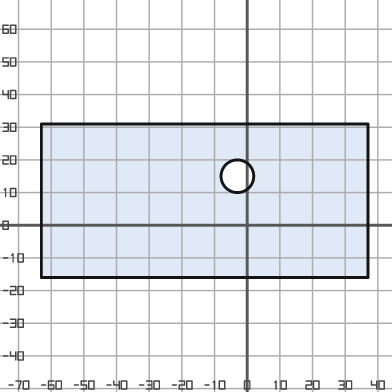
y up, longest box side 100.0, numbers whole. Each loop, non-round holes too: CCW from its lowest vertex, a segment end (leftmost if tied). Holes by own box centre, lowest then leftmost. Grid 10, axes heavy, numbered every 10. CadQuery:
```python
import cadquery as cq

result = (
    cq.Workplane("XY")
    .moveTo(-63.0, -16.0)
    .lineTo(37.0, -16.0)
    .lineTo(37.0, 31.0)
    .lineTo(-63.0, 31.0)
    .close()
    .moveTo(-3.0, 15.0)
    .circle(5.0)
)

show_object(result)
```